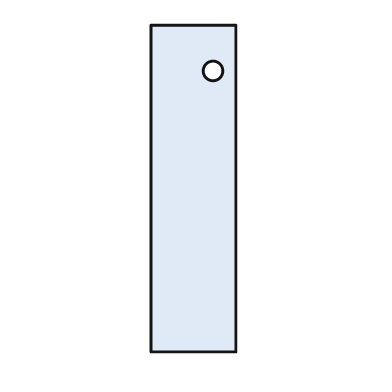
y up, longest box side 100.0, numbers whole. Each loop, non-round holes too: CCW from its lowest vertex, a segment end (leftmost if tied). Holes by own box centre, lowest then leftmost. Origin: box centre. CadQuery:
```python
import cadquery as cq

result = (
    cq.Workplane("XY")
    .moveTo(-13.0, -50.0)
    .lineTo(13.0, -50.0)
    .lineTo(13.0, 50.0)
    .lineTo(-13.0, 50.0)
    .close()
    .moveTo(6.0, 36.0)
    .circle(3.0)
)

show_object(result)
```